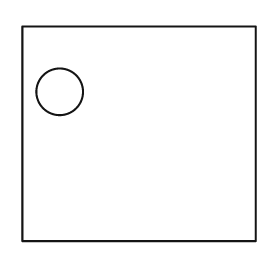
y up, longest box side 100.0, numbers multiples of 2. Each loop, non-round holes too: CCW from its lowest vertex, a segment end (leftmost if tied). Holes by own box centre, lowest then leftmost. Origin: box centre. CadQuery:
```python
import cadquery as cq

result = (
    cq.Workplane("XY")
    .moveTo(-50.0, -46.0)
    .lineTo(50.0, -46.0)
    .lineTo(50.0, 46.0)
    .lineTo(-50.0, 46.0)
    .close()
    .moveTo(-34.0, 18.0)
    .circle(10.0)
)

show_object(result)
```